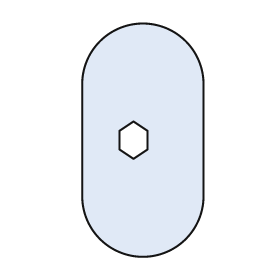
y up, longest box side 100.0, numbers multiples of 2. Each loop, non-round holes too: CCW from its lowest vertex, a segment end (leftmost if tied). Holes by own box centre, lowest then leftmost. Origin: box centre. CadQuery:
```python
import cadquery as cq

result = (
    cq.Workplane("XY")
    .moveTo(-26.0, -24.0)
    .threePointArc((0.0, -50.0), (26.0, -24.0))
    .lineTo(26.0, 24.0)
    .threePointArc((0.0, 50.0), (-26.0, 24.0))
    .close()
    .moveTo(-4.0, -8.0)
    .lineTo(2.0, -4.0)
    .lineTo(2.0, 4.0)
    .lineTo(-4.0, 8.0)
    .lineTo(-10.0, 4.0)
    .lineTo(-10.0, -4.0)
    .close()
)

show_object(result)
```